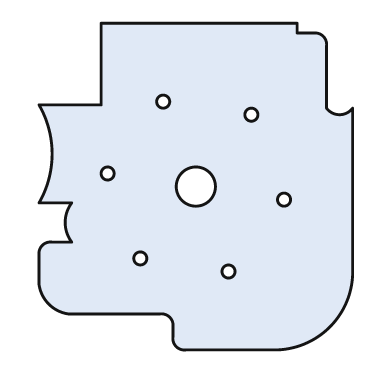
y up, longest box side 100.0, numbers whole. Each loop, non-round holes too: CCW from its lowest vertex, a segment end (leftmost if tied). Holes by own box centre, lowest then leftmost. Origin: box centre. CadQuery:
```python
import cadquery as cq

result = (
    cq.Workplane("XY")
    .moveTo(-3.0, -50.0)
    .lineTo(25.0, -50.0)
    .threePointArc((41.0, -43.0), (48.0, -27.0))
    .lineTo(48.0, 24.0)
    .threePointArc((44.0, 22.0), (40.0, 24.0))
    .lineTo(40.0, 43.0)
    .threePointArc((39.0, 46.0), (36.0, 47.0))
    .lineTo(31.0, 47.0)
    .lineTo(31.0, 50.0)
    .lineTo(-29.0, 50.0)
    .lineTo(-29.0, 25.0)
    .lineTo(-48.0, 25.0)
    .threePointArc((-44.0, 10.0), (-48.0, -5.0))
    .lineTo(-38.0, -5.0)
    .threePointArc((-40.0, -11.0), (-38.0, -17.0))
    .lineTo(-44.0, -17.0)
    .threePointArc((-47.0, -18.0), (-48.0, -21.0))
    .lineTo(-48.0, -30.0)
    .threePointArc((-45.0, -36.0), (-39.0, -39.0))
    .lineTo(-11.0, -39.0)
    .threePointArc((-8.0, -40.0), (-7.0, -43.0))
    .lineTo(-7.0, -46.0)
    .threePointArc((-6.0, -49.0), (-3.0, -50.0))
    .close()
    .moveTo(10.0, -26.0)
    .circle(2.0)
    .moveTo(-17.0, -22.0)
    .circle(2.0)
    .moveTo(27.0, -4.0)
    .circle(2.0)
    .moveTo(0.0, 0.0)
    .circle(6.0)
    .moveTo(-27.0, 4.0)
    .circle(2.0)
    .moveTo(17.0, 22.0)
    .circle(2.0)
    .moveTo(-10.0, 26.0)
    .circle(2.0)
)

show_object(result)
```